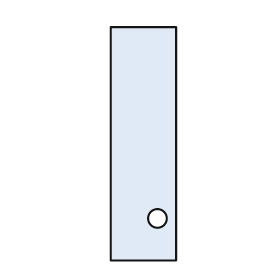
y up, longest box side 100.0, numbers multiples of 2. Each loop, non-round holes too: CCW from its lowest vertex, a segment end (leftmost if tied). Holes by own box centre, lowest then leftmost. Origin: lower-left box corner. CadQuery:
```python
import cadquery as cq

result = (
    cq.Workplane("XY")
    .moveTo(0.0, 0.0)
    .lineTo(28.0, 0.0)
    .lineTo(28.0, 100.0)
    .lineTo(0.0, 100.0)
    .close()
    .moveTo(20.0, 18.0)
    .circle(4.0)
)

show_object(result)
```